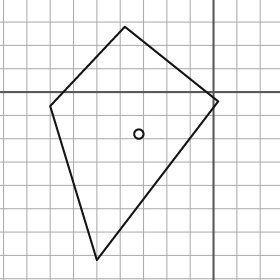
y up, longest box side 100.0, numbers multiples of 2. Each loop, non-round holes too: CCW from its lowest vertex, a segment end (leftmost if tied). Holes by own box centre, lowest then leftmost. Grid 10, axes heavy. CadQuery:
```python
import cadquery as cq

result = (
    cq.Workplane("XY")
    .moveTo(-50.0, -72.0)
    .lineTo(2.0, -4.0)
    .lineTo(-38.0, 28.0)
    .lineTo(-70.0, -6.0)
    .close()
    .moveTo(-32.0, -18.0)
    .circle(2.0)
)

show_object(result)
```